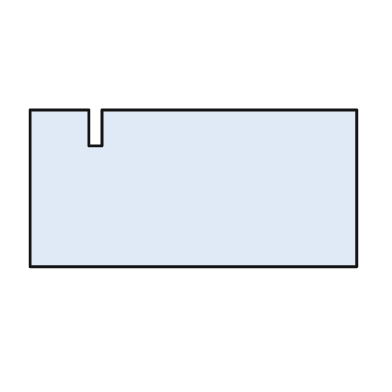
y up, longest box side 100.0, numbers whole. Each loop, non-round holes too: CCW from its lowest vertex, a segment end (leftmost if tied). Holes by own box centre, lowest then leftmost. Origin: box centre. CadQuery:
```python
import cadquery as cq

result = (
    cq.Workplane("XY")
    .moveTo(-50.0, -24.0)
    .lineTo(50.0, -24.0)
    .lineTo(50.0, 24.0)
    .lineTo(-28.0, 24.0)
    .lineTo(-28.0, 13.0)
    .lineTo(-32.0, 13.0)
    .lineTo(-32.0, 24.0)
    .lineTo(-50.0, 24.0)
    .close()
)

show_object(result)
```